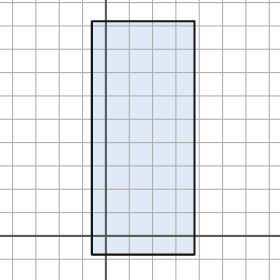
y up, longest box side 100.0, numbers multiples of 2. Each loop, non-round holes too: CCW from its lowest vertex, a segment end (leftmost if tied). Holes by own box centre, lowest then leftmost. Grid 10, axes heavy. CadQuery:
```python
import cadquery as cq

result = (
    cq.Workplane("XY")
    .moveTo(-6.0, -8.0)
    .lineTo(38.0, -8.0)
    .lineTo(38.0, 92.0)
    .lineTo(-6.0, 92.0)
    .close()
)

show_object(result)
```